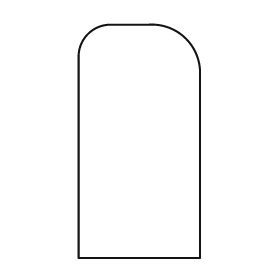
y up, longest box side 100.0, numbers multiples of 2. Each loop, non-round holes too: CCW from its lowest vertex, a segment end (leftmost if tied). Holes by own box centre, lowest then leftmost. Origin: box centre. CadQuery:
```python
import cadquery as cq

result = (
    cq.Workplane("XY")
    .moveTo(-26.0, -50.0)
    .lineTo(26.0, -50.0)
    .lineTo(26.0, 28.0)
    .threePointArc((20.0, 44.0), (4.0, 50.0))
    .lineTo(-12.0, 50.0)
    .threePointArc((-22.0, 46.0), (-26.0, 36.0))
    .close()
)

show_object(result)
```